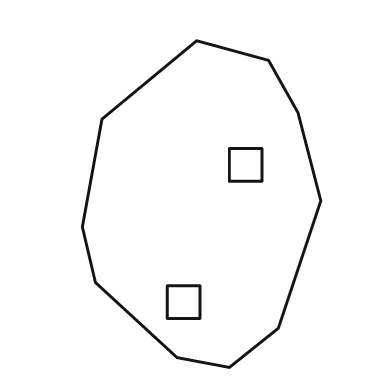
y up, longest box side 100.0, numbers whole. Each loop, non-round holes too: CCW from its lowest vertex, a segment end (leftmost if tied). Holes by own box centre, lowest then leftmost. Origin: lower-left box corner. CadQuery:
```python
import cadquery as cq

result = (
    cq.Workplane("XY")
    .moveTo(45.0, 0.0)
    .lineTo(60.0, 12.0)
    .lineTo(73.0, 51.0)
    .lineTo(66.0, 78.0)
    .lineTo(57.0, 94.0)
    .lineTo(35.0, 100.0)
    .lineTo(6.0, 76.0)
    .lineTo(0.0, 43.0)
    .lineTo(4.0, 26.0)
    .lineTo(29.0, 3.0)
    .close()
    .moveTo(26.0, 15.0)
    .lineTo(36.0, 15.0)
    .lineTo(36.0, 25.0)
    .lineTo(26.0, 25.0)
    .close()
    .moveTo(45.0, 57.0)
    .lineTo(55.0, 57.0)
    .lineTo(55.0, 67.0)
    .lineTo(45.0, 67.0)
    .close()
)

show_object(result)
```